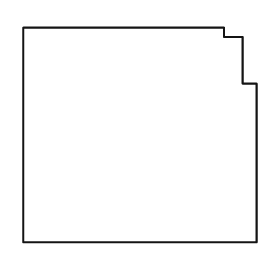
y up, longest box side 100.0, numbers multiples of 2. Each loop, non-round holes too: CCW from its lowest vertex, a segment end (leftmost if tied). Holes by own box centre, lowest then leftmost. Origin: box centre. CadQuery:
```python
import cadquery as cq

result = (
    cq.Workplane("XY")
    .moveTo(-50.0, -46.0)
    .lineTo(50.0, -46.0)
    .lineTo(50.0, 22.0)
    .lineTo(44.0, 22.0)
    .lineTo(44.0, 42.0)
    .lineTo(36.0, 42.0)
    .lineTo(36.0, 46.0)
    .lineTo(-50.0, 46.0)
    .close()
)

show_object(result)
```